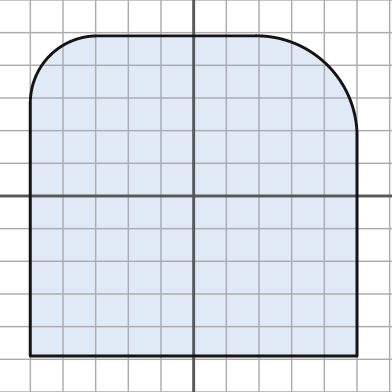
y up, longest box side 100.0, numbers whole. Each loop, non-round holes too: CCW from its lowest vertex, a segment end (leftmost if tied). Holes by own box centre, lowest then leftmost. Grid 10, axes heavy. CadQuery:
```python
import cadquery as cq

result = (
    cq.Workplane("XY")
    .moveTo(-50.0, -49.0)
    .lineTo(50.0, -49.0)
    .lineTo(50.0, 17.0)
    .threePointArc((41.0, 40.0), (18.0, 49.0))
    .lineTo(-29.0, 49.0)
    .threePointArc((-44.0, 43.0), (-50.0, 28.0))
    .close()
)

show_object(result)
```